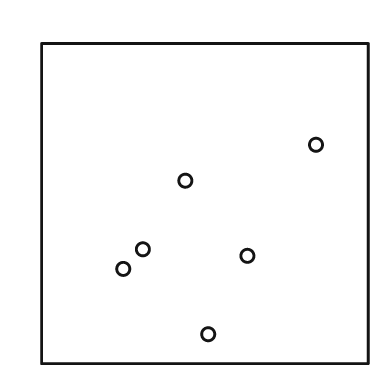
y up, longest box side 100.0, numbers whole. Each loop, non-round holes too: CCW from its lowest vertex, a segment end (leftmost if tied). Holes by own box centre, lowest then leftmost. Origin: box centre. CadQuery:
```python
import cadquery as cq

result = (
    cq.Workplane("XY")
    .moveTo(-50.0, -49.0)
    .lineTo(50.0, -49.0)
    .lineTo(50.0, 49.0)
    .lineTo(-50.0, 49.0)
    .close()
    .moveTo(1.0, -40.0)
    .circle(2.0)
    .moveTo(-25.0, -20.0)
    .circle(2.0)
    .moveTo(13.0, -16.0)
    .circle(2.0)
    .moveTo(-19.0, -14.0)
    .circle(2.0)
    .moveTo(-6.0, 7.0)
    .circle(2.0)
    .moveTo(34.0, 18.0)
    .circle(2.0)
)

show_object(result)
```